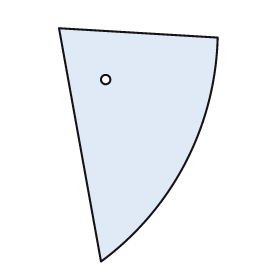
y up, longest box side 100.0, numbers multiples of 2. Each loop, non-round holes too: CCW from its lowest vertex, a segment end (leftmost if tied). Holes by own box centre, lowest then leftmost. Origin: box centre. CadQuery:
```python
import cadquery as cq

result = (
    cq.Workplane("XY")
    .moveTo(-16.0, -50.0)
    .threePointArc((20.0, -8.0), (34.0, 46.0))
    .lineTo(-34.0, 50.0)
    .close()
    .moveTo(-14.0, 28.0)
    .circle(2.0)
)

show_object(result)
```